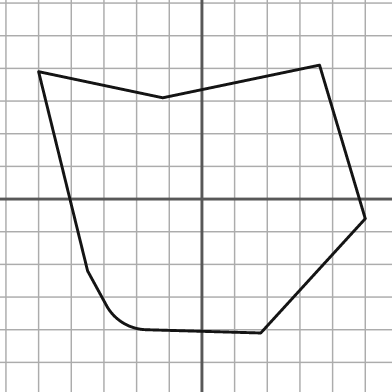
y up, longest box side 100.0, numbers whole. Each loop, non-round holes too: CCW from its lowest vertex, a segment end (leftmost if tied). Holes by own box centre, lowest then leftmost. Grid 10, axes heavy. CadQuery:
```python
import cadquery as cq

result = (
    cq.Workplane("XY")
    .moveTo(18.0, -41.0)
    .lineTo(50.0, -6.0)
    .lineTo(36.0, 41.0)
    .lineTo(-12.0, 31.0)
    .lineTo(-50.0, 39.0)
    .lineTo(-35.0, -22.0)
    .lineTo(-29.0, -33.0)
    .threePointArc((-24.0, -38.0), (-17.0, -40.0))
    .close()
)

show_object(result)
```